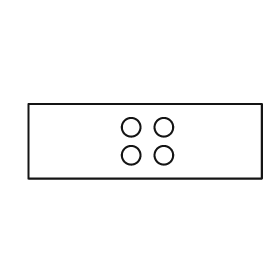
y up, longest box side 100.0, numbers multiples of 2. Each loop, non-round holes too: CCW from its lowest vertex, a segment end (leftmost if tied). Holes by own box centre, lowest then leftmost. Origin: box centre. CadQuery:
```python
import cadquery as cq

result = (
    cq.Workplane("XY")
    .moveTo(-50.0, -16.0)
    .lineTo(50.0, -16.0)
    .lineTo(50.0, 16.0)
    .lineTo(-50.0, 16.0)
    .close()
    .moveTo(-6.0, -6.0)
    .circle(4.0)
    .moveTo(8.0, -6.0)
    .circle(4.0)
    .moveTo(-6.0, 6.0)
    .circle(4.0)
    .moveTo(8.0, 6.0)
    .circle(4.0)
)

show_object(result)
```